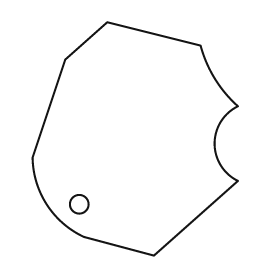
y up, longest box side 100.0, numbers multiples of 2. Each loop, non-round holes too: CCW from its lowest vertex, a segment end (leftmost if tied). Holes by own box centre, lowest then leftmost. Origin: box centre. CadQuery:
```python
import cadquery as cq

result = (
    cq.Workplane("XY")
    .moveTo(8.0, -50.0)
    .lineTo(44.0, -18.0)
    .threePointArc((34.0, -2.0), (44.0, 14.0))
    .threePointArc((34.0, 26.0), (28.0, 40.0))
    .lineTo(-12.0, 50.0)
    .lineTo(-30.0, 34.0)
    .lineTo(-44.0, -8.0)
    .threePointArc((-38.0, -28.0), (-22.0, -42.0))
    .close()
    .moveTo(-24.0, -28.0)
    .circle(4.0)
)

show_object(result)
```